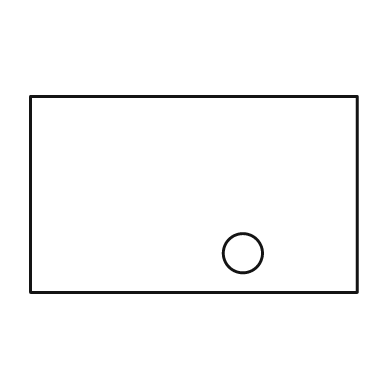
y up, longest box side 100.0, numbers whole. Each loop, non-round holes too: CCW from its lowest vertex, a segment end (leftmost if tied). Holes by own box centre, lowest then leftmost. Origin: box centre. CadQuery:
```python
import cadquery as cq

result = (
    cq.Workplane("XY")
    .moveTo(-50.0, -30.0)
    .lineTo(50.0, -30.0)
    .lineTo(50.0, 30.0)
    .lineTo(-50.0, 30.0)
    .close()
    .moveTo(15.0, -18.0)
    .circle(6.0)
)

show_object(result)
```